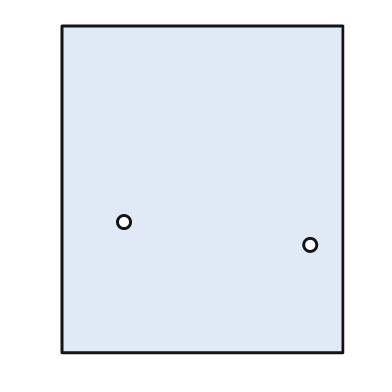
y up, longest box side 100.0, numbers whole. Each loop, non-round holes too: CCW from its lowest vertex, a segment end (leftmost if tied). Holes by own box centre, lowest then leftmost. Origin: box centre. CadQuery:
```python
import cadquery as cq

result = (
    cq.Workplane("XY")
    .moveTo(-43.0, -50.0)
    .lineTo(43.0, -50.0)
    .lineTo(43.0, 50.0)
    .lineTo(-43.0, 50.0)
    .close()
    .moveTo(33.0, -17.0)
    .circle(2.0)
    .moveTo(-24.0, -10.0)
    .circle(2.0)
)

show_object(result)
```